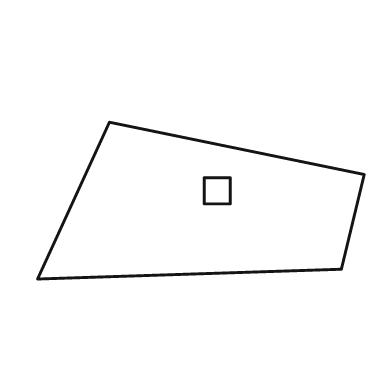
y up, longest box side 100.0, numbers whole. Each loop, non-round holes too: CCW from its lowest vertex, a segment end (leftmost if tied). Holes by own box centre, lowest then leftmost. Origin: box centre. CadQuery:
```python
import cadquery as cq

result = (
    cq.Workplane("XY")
    .moveTo(-50.0, -24.0)
    .lineTo(43.0, -21.0)
    .lineTo(50.0, 8.0)
    .lineTo(-28.0, 24.0)
    .close()
    .moveTo(1.0, -1.0)
    .lineTo(9.0, -1.0)
    .lineTo(9.0, 7.0)
    .lineTo(1.0, 7.0)
    .close()
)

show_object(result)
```